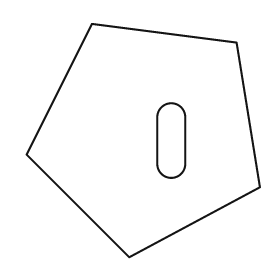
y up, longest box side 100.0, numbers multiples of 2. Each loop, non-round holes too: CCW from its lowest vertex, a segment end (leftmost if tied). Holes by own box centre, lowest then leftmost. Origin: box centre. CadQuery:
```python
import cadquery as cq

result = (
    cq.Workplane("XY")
    .moveTo(-6.0, -50.0)
    .lineTo(50.0, -20.0)
    .lineTo(40.0, 42.0)
    .lineTo(-22.0, 50.0)
    .lineTo(-50.0, -6.0)
    .close()
    .moveTo(6.0, -10.0)
    .threePointArc((12.0, -16.0), (18.0, -10.0))
    .lineTo(18.0, 10.0)
    .threePointArc((12.0, 16.0), (6.0, 10.0))
    .close()
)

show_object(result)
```